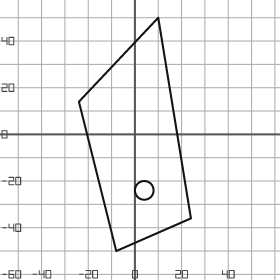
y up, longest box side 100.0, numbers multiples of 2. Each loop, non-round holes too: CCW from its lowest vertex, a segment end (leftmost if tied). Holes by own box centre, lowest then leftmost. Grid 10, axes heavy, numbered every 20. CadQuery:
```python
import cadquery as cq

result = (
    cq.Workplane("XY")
    .moveTo(-8.0, -50.0)
    .lineTo(24.0, -36.0)
    .lineTo(10.0, 50.0)
    .lineTo(-24.0, 14.0)
    .close()
    .moveTo(4.0, -24.0)
    .circle(4.0)
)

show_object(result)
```